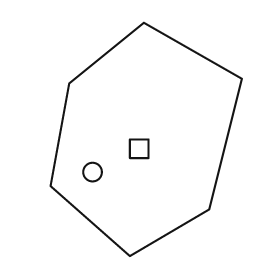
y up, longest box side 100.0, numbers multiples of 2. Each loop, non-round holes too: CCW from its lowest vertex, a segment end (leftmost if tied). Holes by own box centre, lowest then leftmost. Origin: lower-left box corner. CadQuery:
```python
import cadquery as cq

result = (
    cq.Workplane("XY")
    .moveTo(34.0, 0.0)
    .lineTo(68.0, 20.0)
    .lineTo(82.0, 76.0)
    .lineTo(40.0, 100.0)
    .lineTo(8.0, 74.0)
    .lineTo(0.0, 30.0)
    .close()
    .moveTo(18.0, 36.0)
    .circle(4.0)
    .moveTo(34.0, 42.0)
    .lineTo(42.0, 42.0)
    .lineTo(42.0, 50.0)
    .lineTo(34.0, 50.0)
    .close()
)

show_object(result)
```